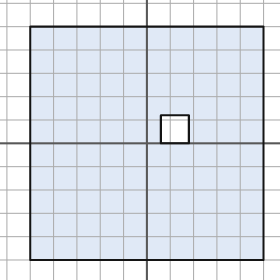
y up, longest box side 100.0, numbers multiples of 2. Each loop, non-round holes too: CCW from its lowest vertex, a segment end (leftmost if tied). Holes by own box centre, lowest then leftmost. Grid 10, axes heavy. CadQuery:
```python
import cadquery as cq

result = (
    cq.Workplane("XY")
    .moveTo(-50.0, -50.0)
    .lineTo(50.0, -50.0)
    .lineTo(50.0, 50.0)
    .lineTo(-50.0, 50.0)
    .close()
    .moveTo(6.0, 0.0)
    .lineTo(18.0, 0.0)
    .lineTo(18.0, 12.0)
    .lineTo(6.0, 12.0)
    .close()
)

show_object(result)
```